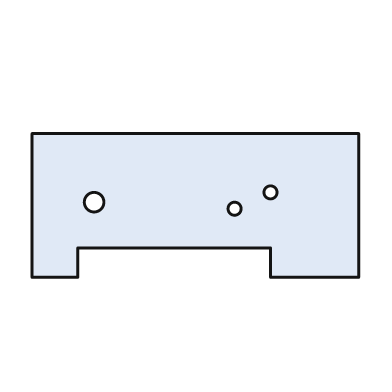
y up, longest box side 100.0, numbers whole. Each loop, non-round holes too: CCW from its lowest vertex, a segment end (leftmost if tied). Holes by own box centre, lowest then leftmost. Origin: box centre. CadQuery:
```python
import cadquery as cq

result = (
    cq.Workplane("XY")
    .moveTo(-50.0, -22.0)
    .lineTo(-36.0, -22.0)
    .lineTo(-36.0, -13.0)
    .lineTo(23.0, -13.0)
    .lineTo(23.0, -22.0)
    .lineTo(50.0, -22.0)
    .lineTo(50.0, 22.0)
    .lineTo(-50.0, 22.0)
    .close()
    .moveTo(12.0, -1.0)
    .circle(2.0)
    .moveTo(-31.0, 1.0)
    .circle(3.0)
    .moveTo(23.0, 4.0)
    .circle(2.0)
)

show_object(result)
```